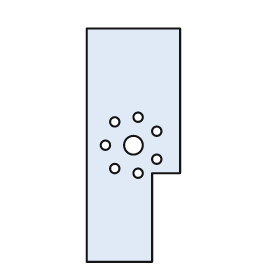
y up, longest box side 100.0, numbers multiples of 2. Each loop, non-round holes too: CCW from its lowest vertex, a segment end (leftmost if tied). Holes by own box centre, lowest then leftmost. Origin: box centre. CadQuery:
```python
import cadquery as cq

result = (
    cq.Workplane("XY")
    .moveTo(-20.0, -50.0)
    .lineTo(8.0, -50.0)
    .lineTo(8.0, -12.0)
    .lineTo(20.0, -12.0)
    .lineTo(20.0, 50.0)
    .lineTo(-20.0, 50.0)
    .close()
    .moveTo(2.0, -12.0)
    .circle(2.0)
    .moveTo(-8.0, -10.0)
    .circle(2.0)
    .moveTo(10.0, -6.0)
    .circle(2.0)
    .moveTo(-12.0, 0.0)
    .circle(2.0)
    .moveTo(0.0, 0.0)
    .circle(4.0)
    .moveTo(10.0, 6.0)
    .circle(2.0)
    .moveTo(-8.0, 10.0)
    .circle(2.0)
    .moveTo(2.0, 12.0)
    .circle(2.0)
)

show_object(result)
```